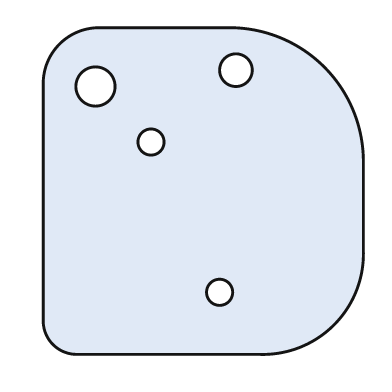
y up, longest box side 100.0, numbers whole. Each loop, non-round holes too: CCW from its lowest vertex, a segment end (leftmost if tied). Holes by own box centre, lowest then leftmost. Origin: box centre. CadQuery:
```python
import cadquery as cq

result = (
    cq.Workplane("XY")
    .moveTo(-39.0, -50.0)
    .lineTo(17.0, -50.0)
    .threePointArc((40.0, -41.0), (49.0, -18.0))
    .lineTo(49.0, 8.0)
    .threePointArc((37.0, 38.0), (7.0, 50.0))
    .lineTo(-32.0, 50.0)
    .threePointArc((-44.0, 45.0), (-49.0, 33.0))
    .lineTo(-49.0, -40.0)
    .threePointArc((-46.0, -47.0), (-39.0, -50.0))
    .close()
    .moveTo(5.0, -31.0)
    .circle(4.0)
    .moveTo(-16.0, 15.0)
    .circle(4.0)
    .moveTo(-33.0, 32.0)
    .circle(6.0)
    .moveTo(10.0, 37.0)
    .circle(5.0)
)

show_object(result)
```